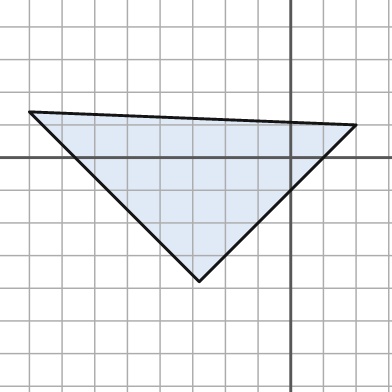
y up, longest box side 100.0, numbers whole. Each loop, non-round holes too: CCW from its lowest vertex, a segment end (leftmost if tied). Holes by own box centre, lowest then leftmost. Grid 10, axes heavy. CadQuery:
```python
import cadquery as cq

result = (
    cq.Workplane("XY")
    .moveTo(-28.0, -38.0)
    .lineTo(20.0, 10.0)
    .lineTo(-80.0, 14.0)
    .close()
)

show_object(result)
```